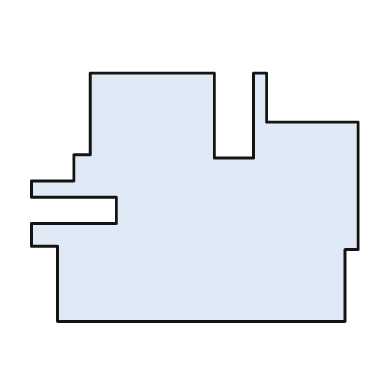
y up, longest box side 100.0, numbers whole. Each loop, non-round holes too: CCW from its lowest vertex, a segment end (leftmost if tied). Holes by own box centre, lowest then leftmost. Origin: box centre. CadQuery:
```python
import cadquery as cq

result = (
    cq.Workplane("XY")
    .moveTo(-42.0, -38.0)
    .lineTo(46.0, -38.0)
    .lineTo(46.0, -16.0)
    .lineTo(50.0, -16.0)
    .lineTo(50.0, 23.0)
    .lineTo(22.0, 23.0)
    .lineTo(22.0, 38.0)
    .lineTo(18.0, 38.0)
    .lineTo(18.0, 12.0)
    .lineTo(6.0, 12.0)
    .lineTo(6.0, 38.0)
    .lineTo(-32.0, 38.0)
    .lineTo(-32.0, 13.0)
    .lineTo(-37.0, 13.0)
    .lineTo(-37.0, 5.0)
    .lineTo(-50.0, 5.0)
    .lineTo(-50.0, 0.0)
    .lineTo(-24.0, 0.0)
    .lineTo(-24.0, -8.0)
    .lineTo(-50.0, -8.0)
    .lineTo(-50.0, -15.0)
    .lineTo(-42.0, -15.0)
    .close()
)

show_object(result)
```